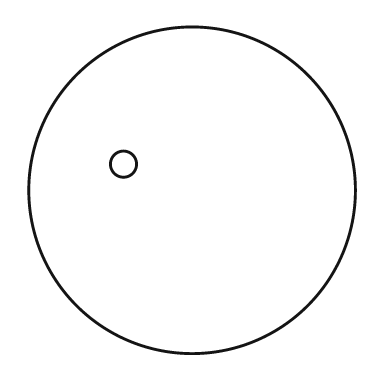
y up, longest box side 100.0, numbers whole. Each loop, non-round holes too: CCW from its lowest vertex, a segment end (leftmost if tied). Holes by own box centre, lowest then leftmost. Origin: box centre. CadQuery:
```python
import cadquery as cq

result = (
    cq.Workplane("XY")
    .moveTo(0.0, 0.0)
    .circle(50.0)
    .moveTo(-21.0, 8.0)
    .circle(4.0)
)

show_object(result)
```